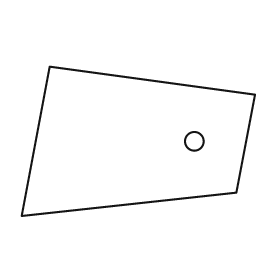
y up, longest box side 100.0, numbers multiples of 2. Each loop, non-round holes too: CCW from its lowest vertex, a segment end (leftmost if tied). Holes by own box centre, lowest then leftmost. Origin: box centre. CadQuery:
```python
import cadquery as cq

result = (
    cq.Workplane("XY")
    .moveTo(-50.0, -32.0)
    .lineTo(42.0, -22.0)
    .lineTo(50.0, 20.0)
    .lineTo(-38.0, 32.0)
    .close()
    .moveTo(24.0, 0.0)
    .circle(4.0)
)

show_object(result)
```